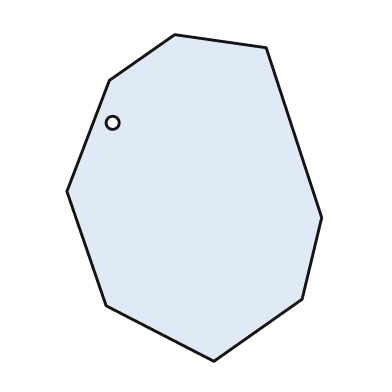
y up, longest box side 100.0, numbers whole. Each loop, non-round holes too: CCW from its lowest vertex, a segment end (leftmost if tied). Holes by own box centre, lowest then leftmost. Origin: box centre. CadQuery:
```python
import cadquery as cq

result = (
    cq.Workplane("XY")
    .moveTo(6.0, -50.0)
    .lineTo(33.0, -31.0)
    .lineTo(39.0, -6.0)
    .lineTo(22.0, 46.0)
    .lineTo(-6.0, 50.0)
    .lineTo(-26.0, 36.0)
    .lineTo(-39.0, 2.0)
    .lineTo(-27.0, -33.0)
    .close()
    .moveTo(-25.0, 23.0)
    .circle(2.0)
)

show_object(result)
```